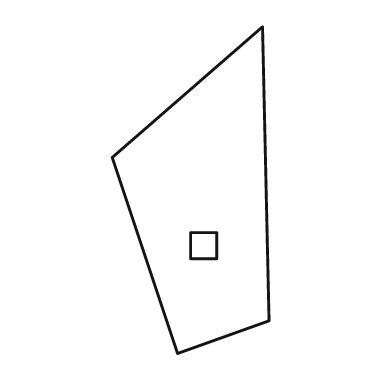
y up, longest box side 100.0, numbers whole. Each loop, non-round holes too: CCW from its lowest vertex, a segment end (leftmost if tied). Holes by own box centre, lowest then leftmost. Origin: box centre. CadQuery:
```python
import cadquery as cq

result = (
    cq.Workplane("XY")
    .moveTo(-4.0, -50.0)
    .lineTo(24.0, -40.0)
    .lineTo(22.0, 50.0)
    .lineTo(-24.0, 10.0)
    .close()
    .moveTo(0.0, -21.0)
    .lineTo(8.0, -21.0)
    .lineTo(8.0, -13.0)
    .lineTo(0.0, -13.0)
    .close()
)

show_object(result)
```